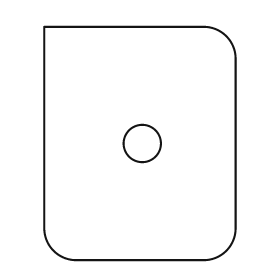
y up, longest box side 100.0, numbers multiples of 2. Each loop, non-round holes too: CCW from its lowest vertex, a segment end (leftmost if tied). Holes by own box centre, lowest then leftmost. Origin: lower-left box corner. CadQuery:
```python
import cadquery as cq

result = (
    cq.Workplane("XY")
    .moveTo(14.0, 0.0)
    .lineTo(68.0, 0.0)
    .threePointArc((78.0, 4.0), (82.0, 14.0))
    .lineTo(82.0, 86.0)
    .threePointArc((78.0, 96.0), (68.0, 100.0))
    .lineTo(0.0, 100.0)
    .lineTo(0.0, 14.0)
    .threePointArc((4.0, 4.0), (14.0, 0.0))
    .close()
    .moveTo(42.0, 50.0)
    .circle(8.0)
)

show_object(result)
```